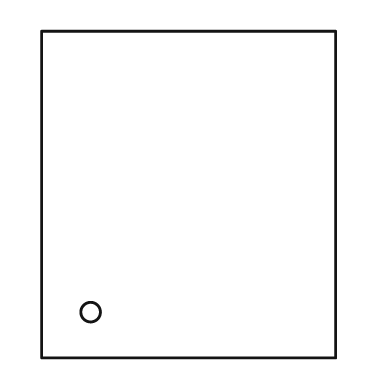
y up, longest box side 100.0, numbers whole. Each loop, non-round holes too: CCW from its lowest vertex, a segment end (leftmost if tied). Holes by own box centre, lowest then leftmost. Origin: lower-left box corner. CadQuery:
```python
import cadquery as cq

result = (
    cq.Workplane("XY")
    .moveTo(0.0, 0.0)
    .lineTo(90.0, 0.0)
    .lineTo(90.0, 100.0)
    .lineTo(0.0, 100.0)
    .close()
    .moveTo(15.0, 14.0)
    .circle(3.0)
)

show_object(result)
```